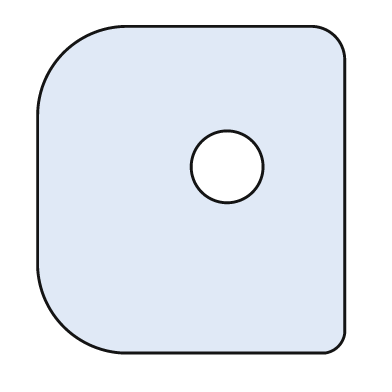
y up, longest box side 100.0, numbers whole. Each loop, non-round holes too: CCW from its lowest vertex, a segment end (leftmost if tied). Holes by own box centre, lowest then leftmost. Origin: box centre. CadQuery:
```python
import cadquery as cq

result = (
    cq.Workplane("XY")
    .moveTo(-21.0, -50.0)
    .lineTo(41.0, -50.0)
    .threePointArc((45.0, -48.0), (47.0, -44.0))
    .lineTo(47.0, 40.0)
    .threePointArc((44.0, 47.0), (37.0, 50.0))
    .lineTo(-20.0, 50.0)
    .threePointArc((-39.0, 42.0), (-47.0, 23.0))
    .lineTo(-47.0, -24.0)
    .threePointArc((-39.0, -42.0), (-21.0, -50.0))
    .close()
    .moveTo(11.0, 7.0)
    .circle(11.0)
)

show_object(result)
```